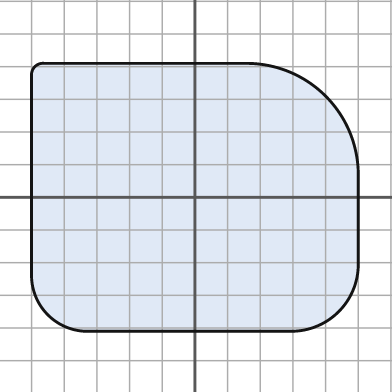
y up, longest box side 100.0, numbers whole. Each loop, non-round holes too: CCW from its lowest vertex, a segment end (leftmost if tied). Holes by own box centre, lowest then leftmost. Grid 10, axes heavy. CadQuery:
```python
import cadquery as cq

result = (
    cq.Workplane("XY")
    .moveTo(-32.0, -41.0)
    .lineTo(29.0, -41.0)
    .threePointArc((44.0, -35.0), (50.0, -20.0))
    .lineTo(50.0, 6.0)
    .threePointArc((40.0, 31.0), (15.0, 41.0))
    .lineTo(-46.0, 41.0)
    .threePointArc((-49.0, 40.0), (-50.0, 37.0))
    .lineTo(-50.0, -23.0)
    .threePointArc((-45.0, -36.0), (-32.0, -41.0))
    .close()
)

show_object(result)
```